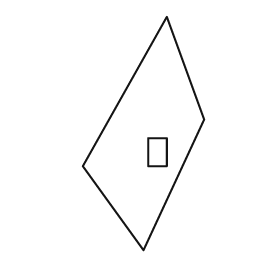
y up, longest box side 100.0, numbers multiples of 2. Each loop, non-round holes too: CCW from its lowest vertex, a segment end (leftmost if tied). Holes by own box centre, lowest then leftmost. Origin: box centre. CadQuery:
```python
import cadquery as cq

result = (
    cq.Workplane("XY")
    .moveTo(0.0, -50.0)
    .lineTo(26.0, 6.0)
    .lineTo(10.0, 50.0)
    .lineTo(-26.0, -14.0)
    .close()
    .moveTo(2.0, -14.0)
    .lineTo(10.0, -14.0)
    .lineTo(10.0, -2.0)
    .lineTo(2.0, -2.0)
    .close()
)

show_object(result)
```